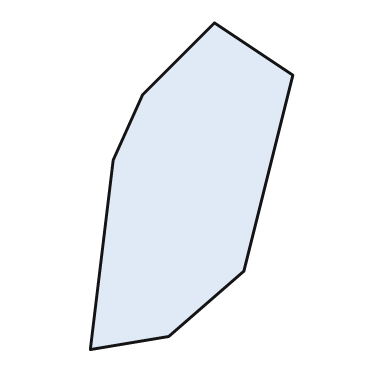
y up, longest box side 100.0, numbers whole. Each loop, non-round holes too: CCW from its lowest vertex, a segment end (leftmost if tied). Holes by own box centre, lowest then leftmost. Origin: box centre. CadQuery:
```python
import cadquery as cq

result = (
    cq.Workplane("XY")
    .moveTo(-31.0, -50.0)
    .lineTo(-7.0, -46.0)
    .lineTo(16.0, -26.0)
    .lineTo(31.0, 34.0)
    .lineTo(7.0, 50.0)
    .lineTo(-15.0, 28.0)
    .lineTo(-24.0, 8.0)
    .close()
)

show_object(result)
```